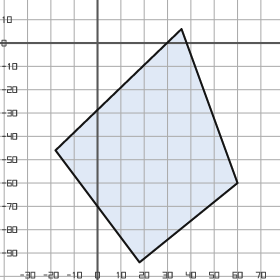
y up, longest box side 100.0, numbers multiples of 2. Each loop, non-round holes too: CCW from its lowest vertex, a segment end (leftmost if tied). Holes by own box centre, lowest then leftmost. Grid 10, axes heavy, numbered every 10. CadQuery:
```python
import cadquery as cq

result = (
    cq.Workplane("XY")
    .moveTo(18.0, -94.0)
    .lineTo(60.0, -60.0)
    .lineTo(36.0, 6.0)
    .lineTo(-18.0, -46.0)
    .close()
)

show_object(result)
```